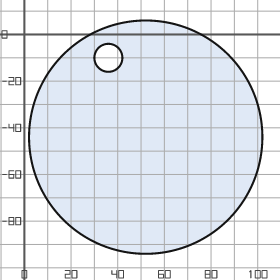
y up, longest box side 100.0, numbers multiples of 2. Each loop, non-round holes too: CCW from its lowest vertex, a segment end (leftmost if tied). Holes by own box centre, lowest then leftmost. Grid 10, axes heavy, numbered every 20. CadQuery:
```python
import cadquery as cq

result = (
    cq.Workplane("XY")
    .moveTo(52.0, -44.0)
    .circle(50.0)
    .moveTo(36.0, -10.0)
    .circle(6.0)
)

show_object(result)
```